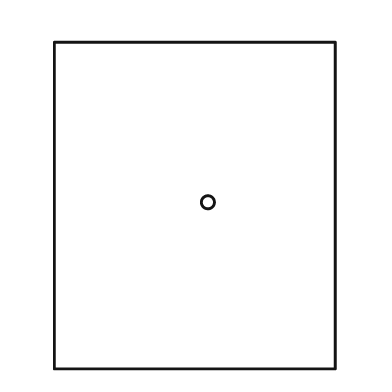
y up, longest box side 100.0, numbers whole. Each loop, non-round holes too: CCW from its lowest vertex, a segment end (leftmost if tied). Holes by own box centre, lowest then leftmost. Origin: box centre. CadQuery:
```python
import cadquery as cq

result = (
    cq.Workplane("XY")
    .moveTo(-43.0, -50.0)
    .lineTo(43.0, -50.0)
    .lineTo(43.0, 50.0)
    .lineTo(-43.0, 50.0)
    .close()
    .moveTo(4.0, 1.0)
    .circle(2.0)
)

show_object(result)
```